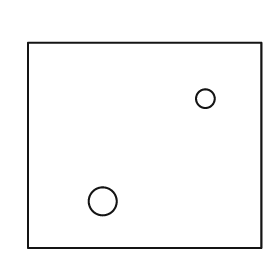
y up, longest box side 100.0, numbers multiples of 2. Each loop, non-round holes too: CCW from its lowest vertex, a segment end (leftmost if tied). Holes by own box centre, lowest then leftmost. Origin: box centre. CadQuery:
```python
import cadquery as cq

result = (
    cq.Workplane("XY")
    .moveTo(-50.0, -44.0)
    .lineTo(50.0, -44.0)
    .lineTo(50.0, 44.0)
    .lineTo(-50.0, 44.0)
    .close()
    .moveTo(-18.0, -24.0)
    .circle(6.0)
    .moveTo(26.0, 20.0)
    .circle(4.0)
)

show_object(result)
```